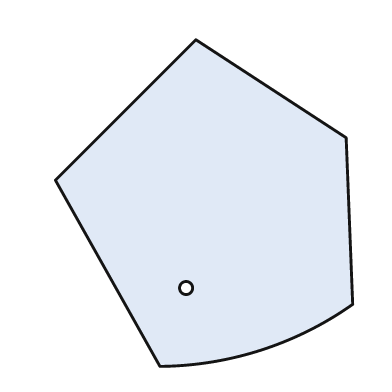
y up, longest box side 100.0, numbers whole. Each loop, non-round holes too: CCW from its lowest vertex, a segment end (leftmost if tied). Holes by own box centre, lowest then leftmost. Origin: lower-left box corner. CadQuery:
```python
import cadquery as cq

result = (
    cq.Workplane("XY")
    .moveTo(32.0, 0.0)
    .threePointArc((63.0, 5.0), (91.0, 19.0))
    .lineTo(89.0, 70.0)
    .lineTo(43.0, 100.0)
    .lineTo(0.0, 57.0)
    .close()
    .moveTo(40.0, 24.0)
    .circle(2.0)
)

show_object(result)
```